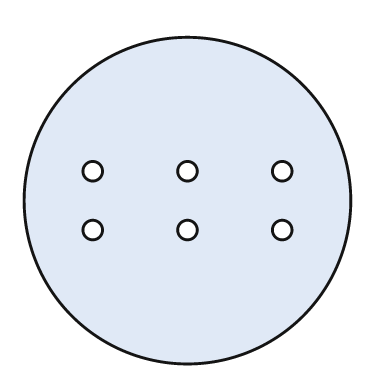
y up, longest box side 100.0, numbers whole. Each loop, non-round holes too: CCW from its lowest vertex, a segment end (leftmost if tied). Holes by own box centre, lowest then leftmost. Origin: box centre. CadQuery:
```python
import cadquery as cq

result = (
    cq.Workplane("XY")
    .moveTo(0.0, 0.0)
    .circle(50.0)
    .moveTo(-29.0, -9.0)
    .circle(3.0)
    .moveTo(0.0, -9.0)
    .circle(3.0)
    .moveTo(29.0, -9.0)
    .circle(3.0)
    .moveTo(-29.0, 9.0)
    .circle(3.0)
    .moveTo(0.0, 9.0)
    .circle(3.0)
    .moveTo(29.0, 9.0)
    .circle(3.0)
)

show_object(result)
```